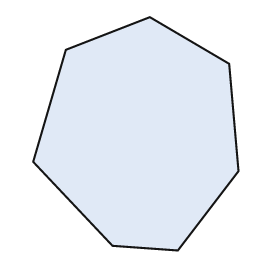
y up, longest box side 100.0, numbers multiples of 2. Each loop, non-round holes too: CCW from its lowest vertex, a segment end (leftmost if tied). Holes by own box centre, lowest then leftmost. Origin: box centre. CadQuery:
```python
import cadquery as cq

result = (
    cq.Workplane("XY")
    .moveTo(18.0, -50.0)
    .lineTo(44.0, -16.0)
    .lineTo(40.0, 30.0)
    .lineTo(6.0, 50.0)
    .lineTo(-30.0, 36.0)
    .lineTo(-44.0, -12.0)
    .lineTo(-10.0, -48.0)
    .close()
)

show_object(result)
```